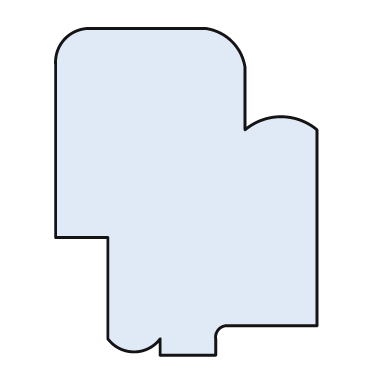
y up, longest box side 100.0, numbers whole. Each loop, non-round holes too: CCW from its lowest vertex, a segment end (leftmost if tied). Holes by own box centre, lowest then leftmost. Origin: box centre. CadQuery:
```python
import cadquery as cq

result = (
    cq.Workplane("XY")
    .moveTo(-8.0, -50.0)
    .lineTo(9.0, -50.0)
    .lineTo(9.0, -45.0)
    .threePointArc((10.0, -42.0), (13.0, -41.0))
    .lineTo(40.0, -41.0)
    .lineTo(40.0, 19.0)
    .threePointArc((29.0, 23.0), (18.0, 19.0))
    .lineTo(18.0, 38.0)
    .threePointArc((14.0, 46.0), (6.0, 50.0))
    .lineTo(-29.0, 50.0)
    .threePointArc((-37.0, 47.0), (-40.0, 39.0))
    .lineTo(-40.0, -14.0)
    .lineTo(-24.0, -14.0)
    .lineTo(-24.0, -45.0)
    .threePointArc((-16.0, -49.0), (-8.0, -45.0))
    .close()
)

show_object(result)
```